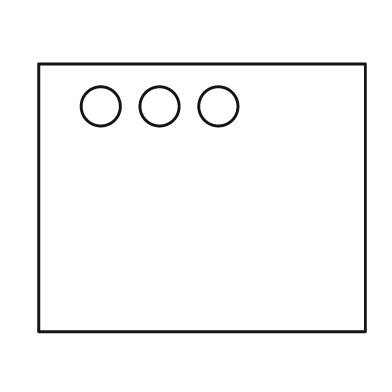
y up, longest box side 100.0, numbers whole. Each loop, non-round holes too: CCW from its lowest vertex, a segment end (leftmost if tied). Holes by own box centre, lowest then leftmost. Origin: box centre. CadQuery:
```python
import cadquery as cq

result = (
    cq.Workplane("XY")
    .moveTo(-50.0, -41.0)
    .lineTo(50.0, -41.0)
    .lineTo(50.0, 41.0)
    .lineTo(-50.0, 41.0)
    .close()
    .moveTo(-31.0, 28.0)
    .circle(6.0)
    .moveTo(-13.0, 28.0)
    .circle(6.0)
    .moveTo(5.0, 28.0)
    .circle(6.0)
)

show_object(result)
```